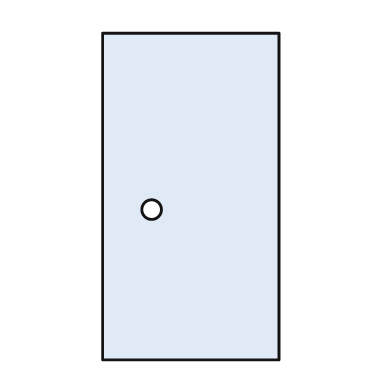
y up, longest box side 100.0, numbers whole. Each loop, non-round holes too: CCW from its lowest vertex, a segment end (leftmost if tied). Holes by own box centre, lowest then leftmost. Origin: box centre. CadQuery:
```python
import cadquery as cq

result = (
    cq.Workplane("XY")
    .moveTo(-27.0, -50.0)
    .lineTo(27.0, -50.0)
    .lineTo(27.0, 50.0)
    .lineTo(-27.0, 50.0)
    .close()
    .moveTo(-12.0, -4.0)
    .circle(3.0)
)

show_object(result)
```